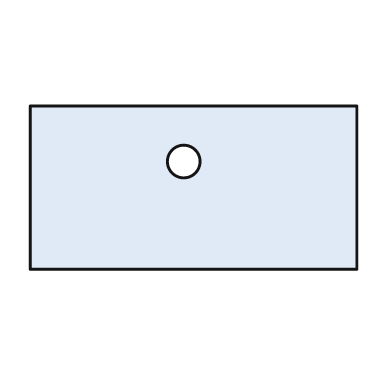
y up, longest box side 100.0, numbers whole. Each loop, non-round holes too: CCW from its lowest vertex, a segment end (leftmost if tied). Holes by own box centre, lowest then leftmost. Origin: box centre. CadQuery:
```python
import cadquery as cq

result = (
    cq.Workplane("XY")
    .moveTo(-50.0, -25.0)
    .lineTo(50.0, -25.0)
    .lineTo(50.0, 25.0)
    .lineTo(-50.0, 25.0)
    .close()
    .moveTo(-3.0, 8.0)
    .circle(5.0)
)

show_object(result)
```